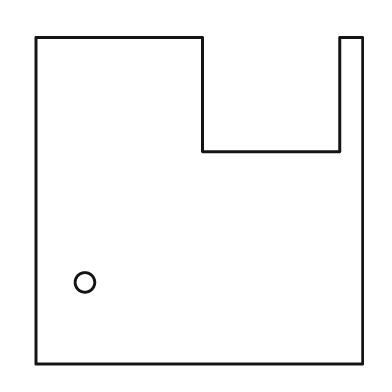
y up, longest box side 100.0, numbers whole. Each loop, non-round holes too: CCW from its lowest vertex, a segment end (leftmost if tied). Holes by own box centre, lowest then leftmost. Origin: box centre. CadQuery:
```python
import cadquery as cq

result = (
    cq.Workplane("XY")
    .moveTo(-50.0, -50.0)
    .lineTo(50.0, -50.0)
    .lineTo(50.0, 50.0)
    .lineTo(43.0, 50.0)
    .lineTo(43.0, 15.0)
    .lineTo(1.0, 15.0)
    .lineTo(1.0, 50.0)
    .lineTo(-50.0, 50.0)
    .close()
    .moveTo(-35.0, -25.0)
    .circle(3.0)
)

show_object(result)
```